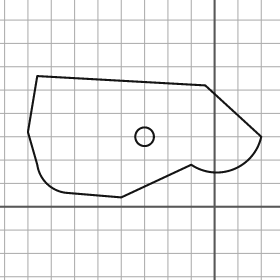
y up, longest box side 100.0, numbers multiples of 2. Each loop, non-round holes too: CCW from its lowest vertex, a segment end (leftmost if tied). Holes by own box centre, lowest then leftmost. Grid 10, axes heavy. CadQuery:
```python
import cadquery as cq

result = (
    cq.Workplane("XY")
    .moveTo(-40.0, 4.0)
    .lineTo(-10.0, 18.0)
    .threePointArc((8.0, 16.0), (20.0, 30.0))
    .lineTo(-4.0, 52.0)
    .lineTo(-76.0, 56.0)
    .lineTo(-80.0, 32.0)
    .lineTo(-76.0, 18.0)
    .threePointArc((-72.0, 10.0), (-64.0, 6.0))
    .close()
    .moveTo(-30.0, 30.0)
    .circle(4.0)
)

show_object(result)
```